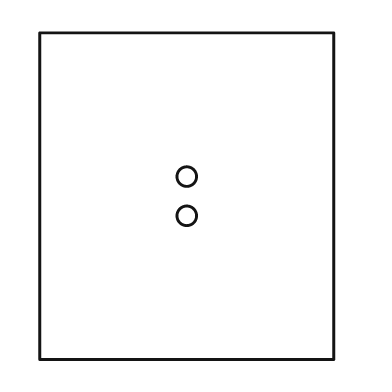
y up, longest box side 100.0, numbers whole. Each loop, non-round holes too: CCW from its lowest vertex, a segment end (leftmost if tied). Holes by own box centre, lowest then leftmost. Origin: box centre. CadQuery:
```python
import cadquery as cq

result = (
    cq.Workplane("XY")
    .moveTo(-45.0, -50.0)
    .lineTo(45.0, -50.0)
    .lineTo(45.0, 50.0)
    .lineTo(-45.0, 50.0)
    .close()
    .moveTo(0.0, -6.0)
    .circle(3.0)
    .moveTo(0.0, 6.0)
    .circle(3.0)
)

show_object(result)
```